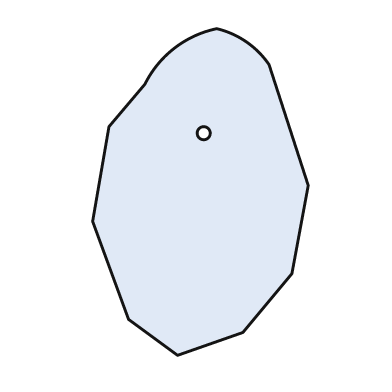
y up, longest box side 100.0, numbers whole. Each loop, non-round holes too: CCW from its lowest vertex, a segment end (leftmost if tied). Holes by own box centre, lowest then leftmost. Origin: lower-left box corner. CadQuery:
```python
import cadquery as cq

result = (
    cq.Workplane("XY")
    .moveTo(26.0, 0.0)
    .lineTo(46.0, 7.0)
    .lineTo(61.0, 25.0)
    .lineTo(66.0, 52.0)
    .lineTo(54.0, 89.0)
    .threePointArc((47.0, 96.0), (38.0, 100.0))
    .threePointArc((25.0, 94.0), (16.0, 83.0))
    .lineTo(5.0, 70.0)
    .lineTo(0.0, 41.0)
    .lineTo(11.0, 11.0)
    .close()
    .moveTo(34.0, 68.0)
    .circle(2.0)
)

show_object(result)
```